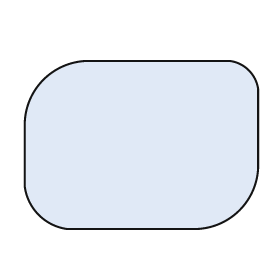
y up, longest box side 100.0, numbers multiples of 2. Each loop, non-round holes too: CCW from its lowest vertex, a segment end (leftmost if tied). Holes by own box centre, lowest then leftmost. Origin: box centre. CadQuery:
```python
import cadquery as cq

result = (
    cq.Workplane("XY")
    .moveTo(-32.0, -36.0)
    .lineTo(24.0, -36.0)
    .threePointArc((42.0, -28.0), (50.0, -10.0))
    .lineTo(50.0, 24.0)
    .threePointArc((46.0, 32.0), (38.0, 36.0))
    .lineTo(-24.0, 36.0)
    .threePointArc((-42.0, 28.0), (-50.0, 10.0))
    .lineTo(-50.0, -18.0)
    .threePointArc((-44.0, -30.0), (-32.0, -36.0))
    .close()
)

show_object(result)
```